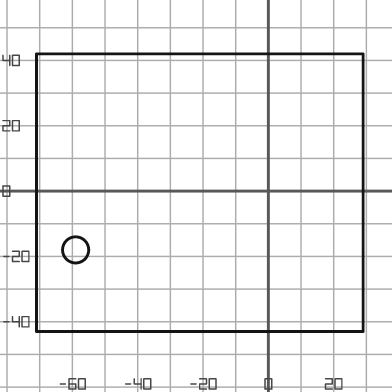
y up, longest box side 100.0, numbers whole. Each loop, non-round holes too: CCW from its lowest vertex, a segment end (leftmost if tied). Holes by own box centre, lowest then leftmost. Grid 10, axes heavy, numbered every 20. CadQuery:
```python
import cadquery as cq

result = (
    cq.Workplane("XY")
    .moveTo(-71.0, -43.0)
    .lineTo(29.0, -43.0)
    .lineTo(29.0, 42.0)
    .lineTo(-71.0, 42.0)
    .close()
    .moveTo(-59.0, -18.0)
    .circle(4.0)
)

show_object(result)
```